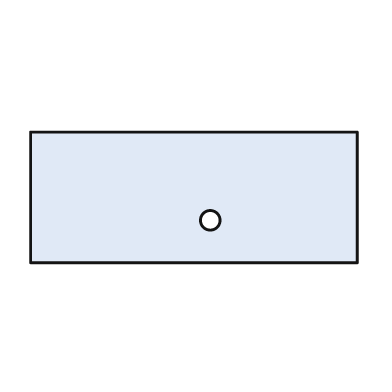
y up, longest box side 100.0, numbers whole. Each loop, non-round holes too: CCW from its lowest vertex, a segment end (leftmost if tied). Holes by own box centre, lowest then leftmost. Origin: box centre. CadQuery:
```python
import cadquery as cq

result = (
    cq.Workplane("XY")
    .moveTo(-50.0, -20.0)
    .lineTo(50.0, -20.0)
    .lineTo(50.0, 20.0)
    .lineTo(-50.0, 20.0)
    .close()
    .moveTo(5.0, -7.0)
    .circle(3.0)
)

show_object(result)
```